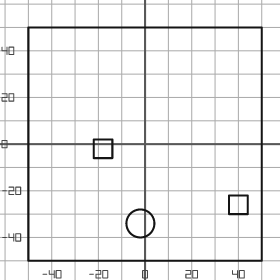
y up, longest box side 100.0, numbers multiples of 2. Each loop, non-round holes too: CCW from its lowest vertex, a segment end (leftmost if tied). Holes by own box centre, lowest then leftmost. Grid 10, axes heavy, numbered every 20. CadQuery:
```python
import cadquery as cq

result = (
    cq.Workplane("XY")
    .moveTo(-50.0, -50.0)
    .lineTo(50.0, -50.0)
    .lineTo(50.0, 50.0)
    .lineTo(-50.0, 50.0)
    .close()
    .moveTo(-2.0, -34.0)
    .circle(6.0)
    .moveTo(36.0, -30.0)
    .lineTo(44.0, -30.0)
    .lineTo(44.0, -22.0)
    .lineTo(36.0, -22.0)
    .close()
    .moveTo(-22.0, -6.0)
    .lineTo(-14.0, -6.0)
    .lineTo(-14.0, 2.0)
    .lineTo(-22.0, 2.0)
    .close()
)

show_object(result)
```